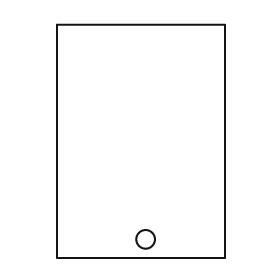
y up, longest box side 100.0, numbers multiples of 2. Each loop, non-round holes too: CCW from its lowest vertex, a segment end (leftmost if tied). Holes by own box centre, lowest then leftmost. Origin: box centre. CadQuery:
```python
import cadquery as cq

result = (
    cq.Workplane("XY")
    .moveTo(-36.0, -50.0)
    .lineTo(36.0, -50.0)
    .lineTo(36.0, 50.0)
    .lineTo(-36.0, 50.0)
    .close()
    .moveTo(2.0, -42.0)
    .circle(4.0)
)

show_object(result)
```